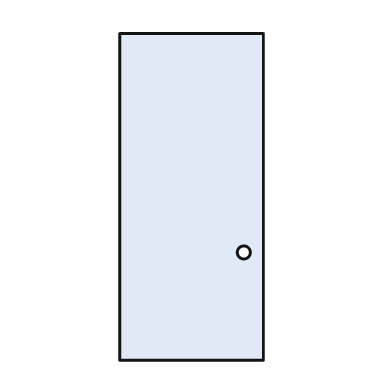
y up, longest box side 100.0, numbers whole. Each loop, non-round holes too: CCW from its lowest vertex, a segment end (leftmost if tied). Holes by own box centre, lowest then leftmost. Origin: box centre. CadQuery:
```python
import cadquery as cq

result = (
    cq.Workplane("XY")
    .moveTo(-22.0, -50.0)
    .lineTo(22.0, -50.0)
    .lineTo(22.0, 50.0)
    .lineTo(-22.0, 50.0)
    .close()
    .moveTo(16.0, -17.0)
    .circle(2.0)
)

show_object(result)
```